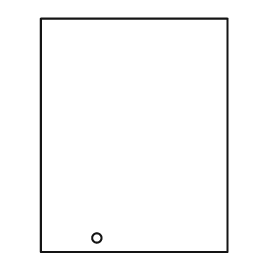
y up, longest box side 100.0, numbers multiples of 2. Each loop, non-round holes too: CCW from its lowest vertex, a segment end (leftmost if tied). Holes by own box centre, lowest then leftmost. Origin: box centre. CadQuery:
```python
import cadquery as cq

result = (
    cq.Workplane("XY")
    .moveTo(-40.0, -50.0)
    .lineTo(40.0, -50.0)
    .lineTo(40.0, 50.0)
    .lineTo(-40.0, 50.0)
    .close()
    .moveTo(-16.0, -44.0)
    .circle(2.0)
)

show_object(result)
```